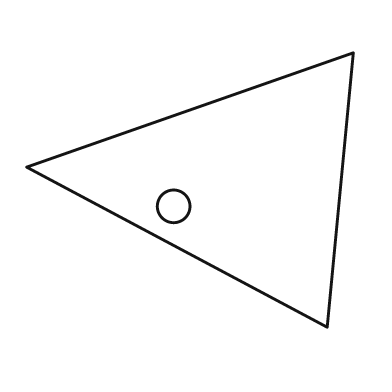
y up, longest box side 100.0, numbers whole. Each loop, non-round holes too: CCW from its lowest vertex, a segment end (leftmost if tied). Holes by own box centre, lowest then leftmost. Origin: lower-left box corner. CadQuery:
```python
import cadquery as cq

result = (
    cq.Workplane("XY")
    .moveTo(92.0, 0.0)
    .lineTo(100.0, 84.0)
    .lineTo(0.0, 49.0)
    .close()
    .moveTo(45.0, 37.0)
    .circle(5.0)
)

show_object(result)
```